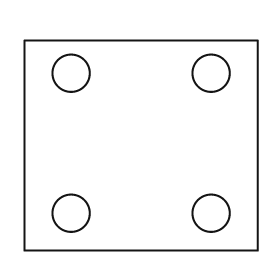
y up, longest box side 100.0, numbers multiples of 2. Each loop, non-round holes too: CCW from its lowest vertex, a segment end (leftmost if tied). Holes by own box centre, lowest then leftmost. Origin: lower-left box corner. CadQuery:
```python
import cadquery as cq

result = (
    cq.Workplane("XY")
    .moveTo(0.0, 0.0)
    .lineTo(100.0, 0.0)
    .lineTo(100.0, 90.0)
    .lineTo(0.0, 90.0)
    .close()
    .moveTo(20.0, 16.0)
    .circle(8.0)
    .moveTo(80.0, 16.0)
    .circle(8.0)
    .moveTo(20.0, 76.0)
    .circle(8.0)
    .moveTo(80.0, 76.0)
    .circle(8.0)
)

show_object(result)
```